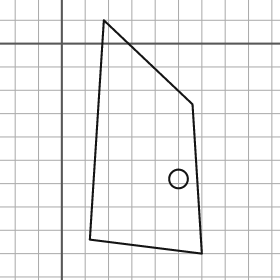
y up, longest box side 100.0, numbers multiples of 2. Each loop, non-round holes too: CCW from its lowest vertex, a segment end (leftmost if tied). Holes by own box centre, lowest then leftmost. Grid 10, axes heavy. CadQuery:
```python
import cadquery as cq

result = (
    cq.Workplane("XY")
    .moveTo(60.0, -90.0)
    .lineTo(56.0, -26.0)
    .lineTo(18.0, 10.0)
    .lineTo(12.0, -84.0)
    .close()
    .moveTo(50.0, -58.0)
    .circle(4.0)
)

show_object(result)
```